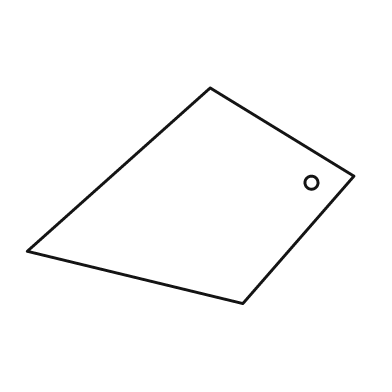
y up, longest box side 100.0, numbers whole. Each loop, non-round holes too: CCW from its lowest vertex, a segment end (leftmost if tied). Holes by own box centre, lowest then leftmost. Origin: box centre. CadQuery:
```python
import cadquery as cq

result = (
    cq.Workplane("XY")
    .moveTo(16.0, -33.0)
    .lineTo(50.0, 6.0)
    .lineTo(6.0, 33.0)
    .lineTo(-50.0, -17.0)
    .close()
    .moveTo(37.0, 4.0)
    .circle(2.0)
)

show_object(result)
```